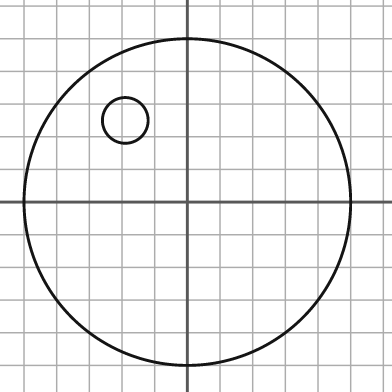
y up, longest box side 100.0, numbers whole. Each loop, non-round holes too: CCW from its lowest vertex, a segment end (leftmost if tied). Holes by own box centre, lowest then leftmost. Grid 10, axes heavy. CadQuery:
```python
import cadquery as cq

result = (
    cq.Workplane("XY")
    .moveTo(0.0, 0.0)
    .circle(50.0)
    .moveTo(-19.0, 25.0)
    .circle(7.0)
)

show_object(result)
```